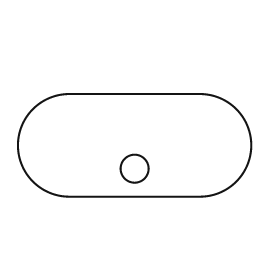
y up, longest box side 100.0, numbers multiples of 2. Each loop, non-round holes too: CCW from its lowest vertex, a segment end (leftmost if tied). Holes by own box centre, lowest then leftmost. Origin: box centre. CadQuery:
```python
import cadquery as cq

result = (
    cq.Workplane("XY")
    .moveTo(-28.0, -22.0)
    .lineTo(28.0, -22.0)
    .threePointArc((50.0, 0.0), (28.0, 22.0))
    .lineTo(-28.0, 22.0)
    .threePointArc((-50.0, 0.0), (-28.0, -22.0))
    .close()
    .moveTo(0.0, -10.0)
    .circle(6.0)
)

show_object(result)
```